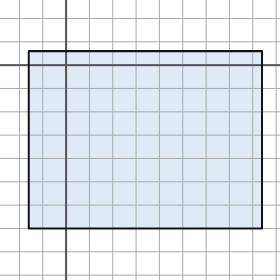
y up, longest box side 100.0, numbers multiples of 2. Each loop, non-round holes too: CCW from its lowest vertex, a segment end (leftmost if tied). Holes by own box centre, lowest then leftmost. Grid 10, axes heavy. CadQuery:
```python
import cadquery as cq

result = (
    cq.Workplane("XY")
    .moveTo(-16.0, -70.0)
    .lineTo(84.0, -70.0)
    .lineTo(84.0, 6.0)
    .lineTo(-16.0, 6.0)
    .close()
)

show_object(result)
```